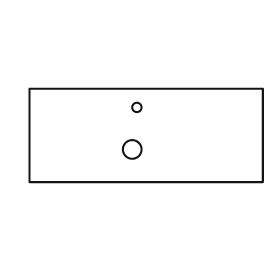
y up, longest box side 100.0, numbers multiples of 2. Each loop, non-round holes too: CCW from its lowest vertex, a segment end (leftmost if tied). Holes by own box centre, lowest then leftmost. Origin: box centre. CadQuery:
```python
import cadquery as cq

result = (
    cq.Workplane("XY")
    .moveTo(-50.0, -20.0)
    .lineTo(50.0, -20.0)
    .lineTo(50.0, 20.0)
    .lineTo(-50.0, 20.0)
    .close()
    .moveTo(-6.0, -6.0)
    .circle(4.0)
    .moveTo(-4.0, 12.0)
    .circle(2.0)
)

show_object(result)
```